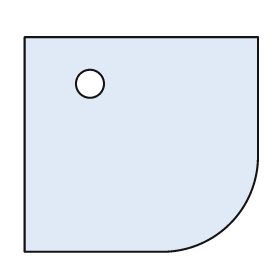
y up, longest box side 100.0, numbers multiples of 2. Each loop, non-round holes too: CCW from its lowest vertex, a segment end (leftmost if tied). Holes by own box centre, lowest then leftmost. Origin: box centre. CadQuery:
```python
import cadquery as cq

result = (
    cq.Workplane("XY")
    .moveTo(-50.0, -46.0)
    .lineTo(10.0, -46.0)
    .threePointArc((38.0, -34.0), (50.0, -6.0))
    .lineTo(50.0, 46.0)
    .lineTo(-50.0, 46.0)
    .close()
    .moveTo(-22.0, 26.0)
    .circle(6.0)
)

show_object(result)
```